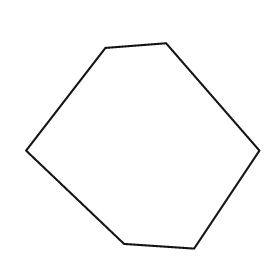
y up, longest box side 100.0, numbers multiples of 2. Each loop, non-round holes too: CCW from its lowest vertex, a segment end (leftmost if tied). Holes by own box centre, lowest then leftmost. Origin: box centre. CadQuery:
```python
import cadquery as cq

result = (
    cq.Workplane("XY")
    .moveTo(22.0, -44.0)
    .lineTo(50.0, -2.0)
    .lineTo(10.0, 44.0)
    .lineTo(-16.0, 42.0)
    .lineTo(-50.0, -2.0)
    .lineTo(-8.0, -42.0)
    .close()
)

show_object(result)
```